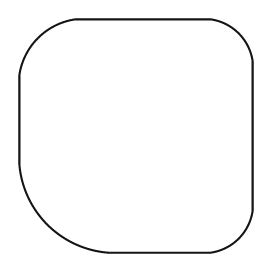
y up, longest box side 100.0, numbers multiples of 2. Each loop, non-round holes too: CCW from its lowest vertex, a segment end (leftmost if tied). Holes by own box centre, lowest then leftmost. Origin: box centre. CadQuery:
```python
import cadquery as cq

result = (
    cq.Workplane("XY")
    .moveTo(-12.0, -50.0)
    .lineTo(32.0, -50.0)
    .threePointArc((44.0, -44.0), (50.0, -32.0))
    .lineTo(50.0, 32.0)
    .threePointArc((44.0, 44.0), (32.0, 50.0))
    .lineTo(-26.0, 50.0)
    .threePointArc((-42.0, 42.0), (-50.0, 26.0))
    .lineTo(-50.0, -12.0)
    .threePointArc((-38.0, -38.0), (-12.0, -50.0))
    .close()
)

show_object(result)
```